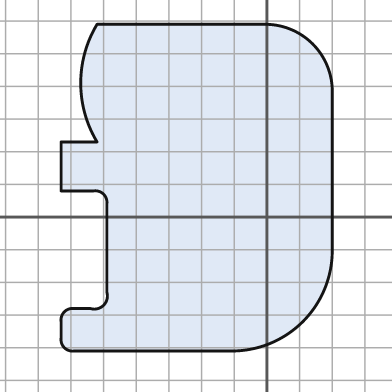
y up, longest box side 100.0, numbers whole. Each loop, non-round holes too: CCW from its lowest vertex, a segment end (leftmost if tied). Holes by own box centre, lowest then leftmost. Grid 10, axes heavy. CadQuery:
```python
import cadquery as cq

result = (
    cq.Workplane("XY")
    .moveTo(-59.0, -41.0)
    .lineTo(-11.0, -41.0)
    .threePointArc((11.0, -32.0), (20.0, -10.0))
    .lineTo(20.0, 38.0)
    .threePointArc((14.0, 53.0), (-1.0, 59.0))
    .lineTo(-52.0, 59.0)
    .threePointArc((-57.0, 41.0), (-52.0, 23.0))
    .lineTo(-63.0, 23.0)
    .lineTo(-63.0, 8.0)
    .lineTo(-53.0, 8.0)
    .threePointArc((-50.0, 7.0), (-49.0, 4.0))
    .lineTo(-49.0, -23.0)
    .threePointArc((-50.0, -27.0), (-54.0, -28.0))
    .lineTo(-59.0, -28.0)
    .threePointArc((-62.0, -29.0), (-63.0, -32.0))
    .lineTo(-63.0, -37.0)
    .threePointArc((-62.0, -40.0), (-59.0, -41.0))
    .close()
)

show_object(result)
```